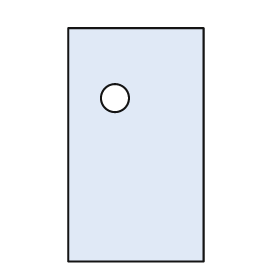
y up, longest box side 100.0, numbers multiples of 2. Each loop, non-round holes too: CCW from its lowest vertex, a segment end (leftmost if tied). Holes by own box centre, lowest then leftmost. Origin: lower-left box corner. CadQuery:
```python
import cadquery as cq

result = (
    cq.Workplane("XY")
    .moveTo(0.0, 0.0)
    .lineTo(58.0, 0.0)
    .lineTo(58.0, 100.0)
    .lineTo(0.0, 100.0)
    .close()
    .moveTo(20.0, 70.0)
    .circle(6.0)
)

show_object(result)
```